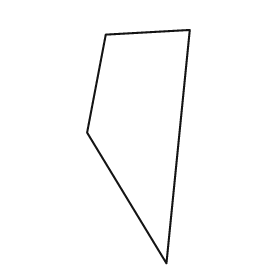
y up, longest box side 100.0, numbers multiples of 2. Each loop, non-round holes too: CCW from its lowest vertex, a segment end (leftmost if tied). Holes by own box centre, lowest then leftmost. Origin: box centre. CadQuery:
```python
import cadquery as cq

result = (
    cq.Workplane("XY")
    .moveTo(12.0, -50.0)
    .lineTo(22.0, 50.0)
    .lineTo(-14.0, 48.0)
    .lineTo(-22.0, 6.0)
    .close()
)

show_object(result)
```